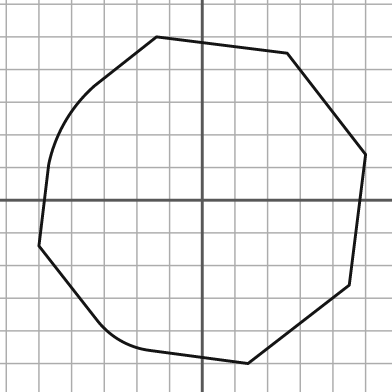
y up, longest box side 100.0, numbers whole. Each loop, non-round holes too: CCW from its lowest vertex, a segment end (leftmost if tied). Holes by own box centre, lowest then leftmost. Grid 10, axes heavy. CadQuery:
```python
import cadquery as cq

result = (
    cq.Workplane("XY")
    .moveTo(14.0, -50.0)
    .lineTo(45.0, -26.0)
    .lineTo(50.0, 14.0)
    .lineTo(26.0, 45.0)
    .lineTo(-14.0, 50.0)
    .lineTo(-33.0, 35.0)
    .threePointArc((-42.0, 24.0), (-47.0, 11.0))
    .lineTo(-50.0, -14.0)
    .lineTo(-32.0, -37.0)
    .threePointArc((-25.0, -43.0), (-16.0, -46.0))
    .close()
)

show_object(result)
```